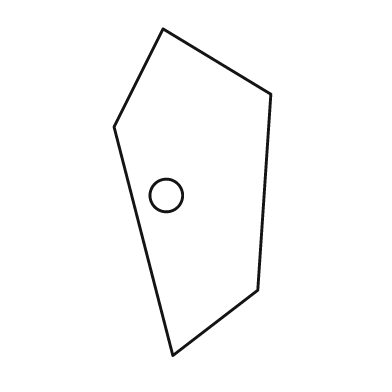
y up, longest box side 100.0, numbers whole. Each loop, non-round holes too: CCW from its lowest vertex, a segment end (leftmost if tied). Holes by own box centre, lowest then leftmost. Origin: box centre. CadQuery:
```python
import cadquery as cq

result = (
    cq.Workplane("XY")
    .moveTo(-6.0, -50.0)
    .lineTo(20.0, -30.0)
    .lineTo(24.0, 30.0)
    .lineTo(-9.0, 50.0)
    .lineTo(-24.0, 20.0)
    .close()
    .moveTo(-8.0, -1.0)
    .circle(5.0)
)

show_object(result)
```